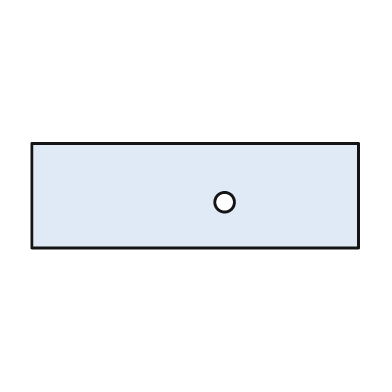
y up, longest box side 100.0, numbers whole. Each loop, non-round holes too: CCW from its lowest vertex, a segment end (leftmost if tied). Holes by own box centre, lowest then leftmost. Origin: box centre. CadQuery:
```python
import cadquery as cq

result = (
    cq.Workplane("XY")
    .moveTo(-50.0, -16.0)
    .lineTo(50.0, -16.0)
    .lineTo(50.0, 16.0)
    .lineTo(-50.0, 16.0)
    .close()
    .moveTo(9.0, -2.0)
    .circle(3.0)
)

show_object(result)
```